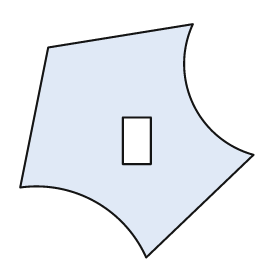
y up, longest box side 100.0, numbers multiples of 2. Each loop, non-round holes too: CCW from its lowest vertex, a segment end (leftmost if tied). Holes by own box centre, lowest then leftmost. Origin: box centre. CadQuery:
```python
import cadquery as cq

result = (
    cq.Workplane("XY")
    .moveTo(4.0, -50.0)
    .lineTo(50.0, -6.0)
    .threePointArc((24.0, 16.0), (24.0, 50.0))
    .lineTo(-38.0, 40.0)
    .lineTo(-50.0, -20.0)
    .threePointArc((-18.0, -26.0), (4.0, -50.0))
    .close()
    .moveTo(-6.0, -10.0)
    .lineTo(6.0, -10.0)
    .lineTo(6.0, 10.0)
    .lineTo(-6.0, 10.0)
    .close()
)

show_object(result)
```